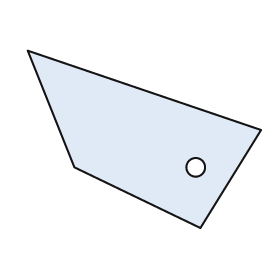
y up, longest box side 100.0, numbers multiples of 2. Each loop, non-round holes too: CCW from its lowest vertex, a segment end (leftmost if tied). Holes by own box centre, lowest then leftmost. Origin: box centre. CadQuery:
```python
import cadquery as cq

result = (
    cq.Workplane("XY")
    .moveTo(24.0, -38.0)
    .lineTo(50.0, 4.0)
    .lineTo(-50.0, 38.0)
    .lineTo(-30.0, -12.0)
    .close()
    .moveTo(22.0, -12.0)
    .circle(4.0)
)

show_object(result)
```